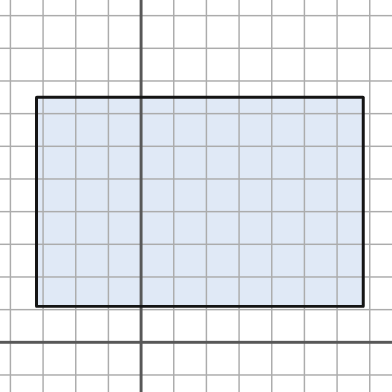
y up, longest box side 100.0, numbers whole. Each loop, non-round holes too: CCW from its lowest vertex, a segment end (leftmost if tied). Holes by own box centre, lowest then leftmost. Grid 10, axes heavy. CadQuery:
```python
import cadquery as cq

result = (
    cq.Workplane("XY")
    .moveTo(-32.0, 11.0)
    .lineTo(68.0, 11.0)
    .lineTo(68.0, 75.0)
    .lineTo(-32.0, 75.0)
    .close()
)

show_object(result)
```